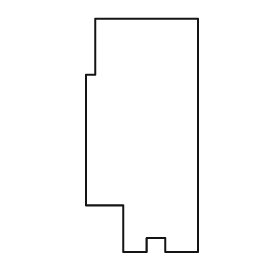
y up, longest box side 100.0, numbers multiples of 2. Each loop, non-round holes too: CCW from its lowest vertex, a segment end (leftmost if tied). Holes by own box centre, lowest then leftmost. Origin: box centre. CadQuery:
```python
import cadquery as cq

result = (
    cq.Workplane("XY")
    .moveTo(-8.0, -50.0)
    .lineTo(2.0, -50.0)
    .lineTo(2.0, -44.0)
    .lineTo(10.0, -44.0)
    .lineTo(10.0, -50.0)
    .lineTo(24.0, -50.0)
    .lineTo(24.0, 50.0)
    .lineTo(-20.0, 50.0)
    .lineTo(-20.0, 26.0)
    .lineTo(-24.0, 26.0)
    .lineTo(-24.0, -30.0)
    .lineTo(-8.0, -30.0)
    .close()
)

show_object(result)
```